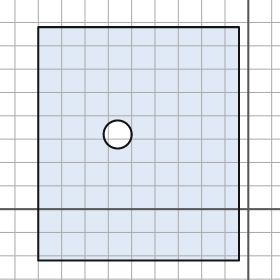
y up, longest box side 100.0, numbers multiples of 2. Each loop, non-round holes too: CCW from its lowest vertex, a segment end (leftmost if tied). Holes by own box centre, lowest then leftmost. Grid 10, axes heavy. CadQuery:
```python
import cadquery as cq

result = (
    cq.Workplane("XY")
    .moveTo(-90.0, -22.0)
    .lineTo(-4.0, -22.0)
    .lineTo(-4.0, 78.0)
    .lineTo(-90.0, 78.0)
    .close()
    .moveTo(-56.0, 32.0)
    .circle(6.0)
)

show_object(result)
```